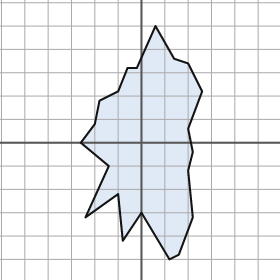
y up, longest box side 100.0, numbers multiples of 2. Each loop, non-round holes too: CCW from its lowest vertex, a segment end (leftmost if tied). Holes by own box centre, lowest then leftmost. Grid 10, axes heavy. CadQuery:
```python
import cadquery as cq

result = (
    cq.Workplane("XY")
    .moveTo(12.0, -50.0)
    .lineTo(16.0, -48.0)
    .lineTo(22.0, -32.0)
    .lineTo(20.0, -12.0)
    .lineTo(22.0, -4.0)
    .lineTo(20.0, 6.0)
    .lineTo(26.0, 22.0)
    .lineTo(20.0, 34.0)
    .lineTo(14.0, 36.0)
    .lineTo(6.0, 50.0)
    .lineTo(-2.0, 32.0)
    .lineTo(-6.0, 32.0)
    .lineTo(-10.0, 22.0)
    .lineTo(-18.0, 18.0)
    .lineTo(-20.0, 8.0)
    .lineTo(-26.0, 0.0)
    .lineTo(-14.0, -10.0)
    .lineTo(-24.0, -32.0)
    .lineTo(-10.0, -22.0)
    .lineTo(-8.0, -42.0)
    .lineTo(0.0, -30.0)
    .close()
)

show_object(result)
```